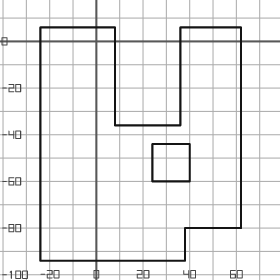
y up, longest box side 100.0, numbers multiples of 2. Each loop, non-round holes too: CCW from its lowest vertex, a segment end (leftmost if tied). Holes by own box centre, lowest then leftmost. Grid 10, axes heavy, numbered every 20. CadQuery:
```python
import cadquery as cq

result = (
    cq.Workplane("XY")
    .moveTo(-24.0, -94.0)
    .lineTo(38.0, -94.0)
    .lineTo(38.0, -80.0)
    .lineTo(62.0, -80.0)
    .lineTo(62.0, 6.0)
    .lineTo(36.0, 6.0)
    .lineTo(36.0, -36.0)
    .lineTo(8.0, -36.0)
    .lineTo(8.0, 6.0)
    .lineTo(-24.0, 6.0)
    .close()
    .moveTo(24.0, -60.0)
    .lineTo(40.0, -60.0)
    .lineTo(40.0, -44.0)
    .lineTo(24.0, -44.0)
    .close()
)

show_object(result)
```